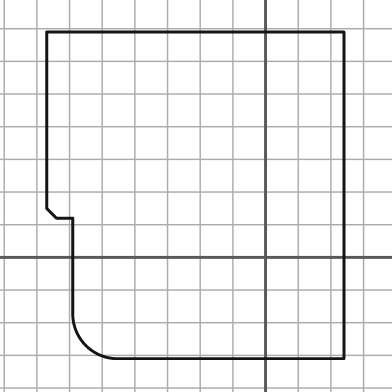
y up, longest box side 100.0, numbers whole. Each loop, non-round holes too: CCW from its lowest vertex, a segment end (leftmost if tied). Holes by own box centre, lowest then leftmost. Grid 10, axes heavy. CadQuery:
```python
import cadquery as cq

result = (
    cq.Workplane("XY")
    .moveTo(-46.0, -31.0)
    .lineTo(24.0, -31.0)
    .lineTo(24.0, 69.0)
    .lineTo(-67.0, 69.0)
    .lineTo(-67.0, 15.0)
    .lineTo(-64.0, 12.0)
    .lineTo(-59.0, 12.0)
    .lineTo(-59.0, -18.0)
    .threePointArc((-55.0, -27.0), (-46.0, -31.0))
    .close()
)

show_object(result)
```